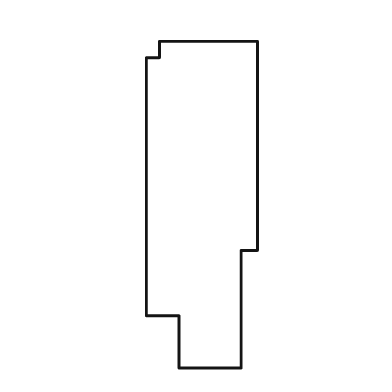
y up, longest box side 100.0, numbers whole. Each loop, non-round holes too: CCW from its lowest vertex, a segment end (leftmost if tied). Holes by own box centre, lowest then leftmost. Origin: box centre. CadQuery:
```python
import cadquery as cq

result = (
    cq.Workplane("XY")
    .moveTo(-7.0, -50.0)
    .lineTo(12.0, -50.0)
    .lineTo(12.0, -14.0)
    .lineTo(17.0, -14.0)
    .lineTo(17.0, 50.0)
    .lineTo(-13.0, 50.0)
    .lineTo(-13.0, 45.0)
    .lineTo(-17.0, 45.0)
    .lineTo(-17.0, -34.0)
    .lineTo(-7.0, -34.0)
    .close()
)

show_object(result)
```